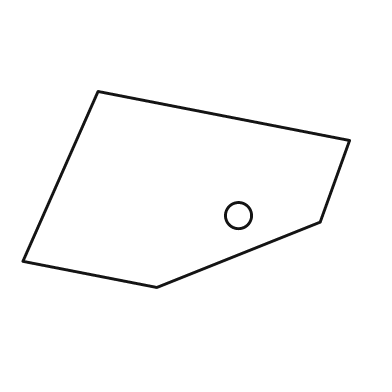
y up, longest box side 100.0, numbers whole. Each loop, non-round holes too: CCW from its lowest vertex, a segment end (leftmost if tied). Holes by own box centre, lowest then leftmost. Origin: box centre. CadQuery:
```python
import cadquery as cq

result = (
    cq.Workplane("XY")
    .moveTo(-9.0, -30.0)
    .lineTo(41.0, -10.0)
    .lineTo(50.0, 15.0)
    .lineTo(-27.0, 30.0)
    .lineTo(-50.0, -22.0)
    .close()
    .moveTo(16.0, -8.0)
    .circle(4.0)
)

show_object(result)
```